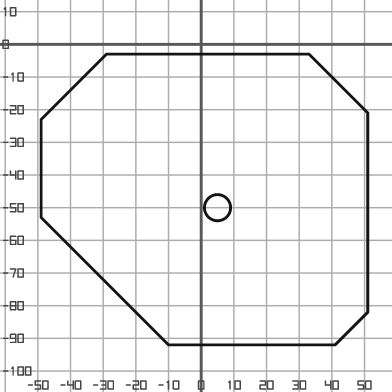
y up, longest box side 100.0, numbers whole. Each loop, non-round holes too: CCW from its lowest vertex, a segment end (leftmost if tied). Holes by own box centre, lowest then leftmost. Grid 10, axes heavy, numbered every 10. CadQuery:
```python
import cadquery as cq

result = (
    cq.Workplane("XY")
    .moveTo(-10.0, -92.0)
    .lineTo(41.0, -92.0)
    .lineTo(51.0, -82.0)
    .lineTo(51.0, -21.0)
    .lineTo(33.0, -3.0)
    .lineTo(-29.0, -3.0)
    .lineTo(-49.0, -23.0)
    .lineTo(-49.0, -53.0)
    .close()
    .moveTo(5.0, -50.0)
    .circle(4.0)
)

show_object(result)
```